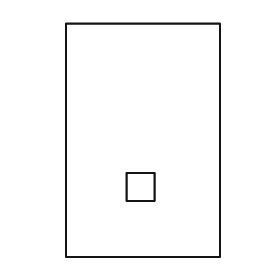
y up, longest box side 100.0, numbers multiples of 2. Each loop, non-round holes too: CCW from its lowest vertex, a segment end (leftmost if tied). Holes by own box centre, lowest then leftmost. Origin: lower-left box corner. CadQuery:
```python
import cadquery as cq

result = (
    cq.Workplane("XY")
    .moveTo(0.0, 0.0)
    .lineTo(66.0, 0.0)
    .lineTo(66.0, 100.0)
    .lineTo(0.0, 100.0)
    .close()
    .moveTo(26.0, 24.0)
    .lineTo(38.0, 24.0)
    .lineTo(38.0, 36.0)
    .lineTo(26.0, 36.0)
    .close()
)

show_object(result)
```